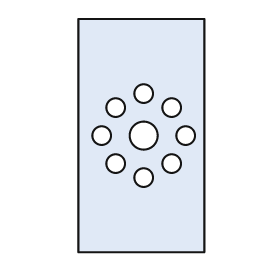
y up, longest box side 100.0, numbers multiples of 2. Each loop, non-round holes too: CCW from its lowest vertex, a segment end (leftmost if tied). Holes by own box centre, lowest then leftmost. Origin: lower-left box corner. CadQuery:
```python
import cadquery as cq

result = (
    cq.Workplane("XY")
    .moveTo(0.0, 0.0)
    .lineTo(54.0, 0.0)
    .lineTo(54.0, 100.0)
    .lineTo(0.0, 100.0)
    .close()
    .moveTo(28.0, 32.0)
    .circle(4.0)
    .moveTo(16.0, 38.0)
    .circle(4.0)
    .moveTo(40.0, 38.0)
    .circle(4.0)
    .moveTo(10.0, 50.0)
    .circle(4.0)
    .moveTo(28.0, 50.0)
    .circle(6.0)
    .moveTo(46.0, 50.0)
    .circle(4.0)
    .moveTo(16.0, 62.0)
    .circle(4.0)
    .moveTo(40.0, 62.0)
    .circle(4.0)
    .moveTo(28.0, 68.0)
    .circle(4.0)
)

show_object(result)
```